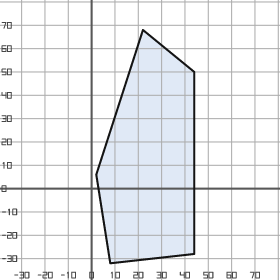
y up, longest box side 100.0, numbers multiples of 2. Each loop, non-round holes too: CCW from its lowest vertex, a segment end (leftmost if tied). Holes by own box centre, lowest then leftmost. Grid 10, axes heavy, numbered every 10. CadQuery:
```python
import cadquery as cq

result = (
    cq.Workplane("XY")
    .moveTo(8.0, -32.0)
    .lineTo(44.0, -28.0)
    .lineTo(44.0, 50.0)
    .lineTo(22.0, 68.0)
    .lineTo(2.0, 6.0)
    .close()
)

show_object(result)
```